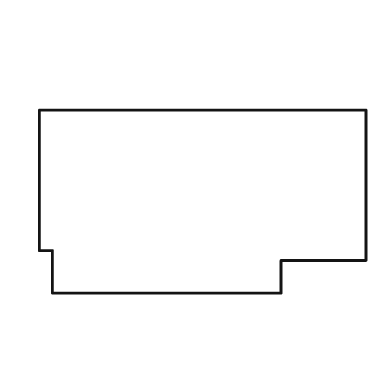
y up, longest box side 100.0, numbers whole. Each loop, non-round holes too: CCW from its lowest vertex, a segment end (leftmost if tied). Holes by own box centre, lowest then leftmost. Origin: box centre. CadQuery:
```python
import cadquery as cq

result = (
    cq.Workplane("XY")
    .moveTo(-46.0, -28.0)
    .lineTo(24.0, -28.0)
    .lineTo(24.0, -18.0)
    .lineTo(50.0, -18.0)
    .lineTo(50.0, 28.0)
    .lineTo(-50.0, 28.0)
    .lineTo(-50.0, -15.0)
    .lineTo(-46.0, -15.0)
    .close()
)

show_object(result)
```